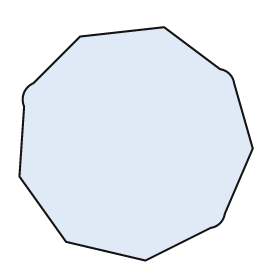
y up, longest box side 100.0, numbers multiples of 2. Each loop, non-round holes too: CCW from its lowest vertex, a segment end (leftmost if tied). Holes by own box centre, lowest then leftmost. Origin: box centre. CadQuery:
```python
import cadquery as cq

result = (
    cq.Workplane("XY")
    .moveTo(4.0, -50.0)
    .lineTo(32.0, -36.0)
    .threePointArc((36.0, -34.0), (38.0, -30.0))
    .lineTo(50.0, -2.0)
    .lineTo(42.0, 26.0)
    .threePointArc((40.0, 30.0), (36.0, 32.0))
    .lineTo(12.0, 50.0)
    .lineTo(-24.0, 46.0)
    .lineTo(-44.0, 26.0)
    .threePointArc((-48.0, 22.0), (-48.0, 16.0))
    .lineTo(-50.0, -14.0)
    .lineTo(-30.0, -42.0)
    .close()
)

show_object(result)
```